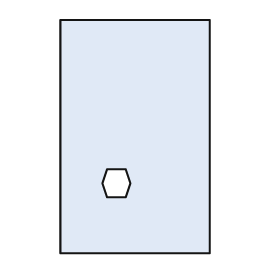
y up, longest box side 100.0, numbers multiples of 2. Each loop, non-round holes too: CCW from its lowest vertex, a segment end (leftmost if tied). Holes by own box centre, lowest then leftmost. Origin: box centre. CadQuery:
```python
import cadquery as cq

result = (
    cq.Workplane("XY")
    .moveTo(-32.0, -50.0)
    .lineTo(32.0, -50.0)
    .lineTo(32.0, 50.0)
    .lineTo(-32.0, 50.0)
    .close()
    .moveTo(-12.0, -26.0)
    .lineTo(-4.0, -26.0)
    .lineTo(-2.0, -20.0)
    .lineTo(-4.0, -14.0)
    .lineTo(-12.0, -14.0)
    .lineTo(-14.0, -20.0)
    .close()
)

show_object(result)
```